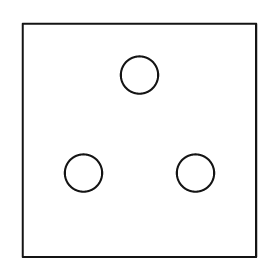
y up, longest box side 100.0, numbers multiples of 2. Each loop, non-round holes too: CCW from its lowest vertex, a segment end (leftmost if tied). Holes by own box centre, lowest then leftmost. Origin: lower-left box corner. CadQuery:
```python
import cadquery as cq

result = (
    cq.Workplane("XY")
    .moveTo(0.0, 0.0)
    .lineTo(100.0, 0.0)
    .lineTo(100.0, 100.0)
    .lineTo(0.0, 100.0)
    .close()
    .moveTo(26.0, 36.0)
    .circle(8.0)
    .moveTo(74.0, 36.0)
    .circle(8.0)
    .moveTo(50.0, 78.0)
    .circle(8.0)
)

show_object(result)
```